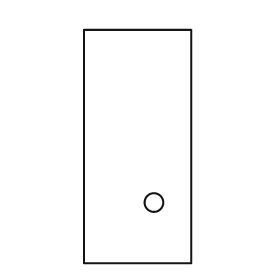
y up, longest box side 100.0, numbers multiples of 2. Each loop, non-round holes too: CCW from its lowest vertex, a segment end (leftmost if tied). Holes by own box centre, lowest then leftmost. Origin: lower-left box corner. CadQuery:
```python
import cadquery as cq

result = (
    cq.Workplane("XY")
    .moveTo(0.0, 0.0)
    .lineTo(46.0, 0.0)
    .lineTo(46.0, 100.0)
    .lineTo(0.0, 100.0)
    .close()
    .moveTo(30.0, 26.0)
    .circle(4.0)
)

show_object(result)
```